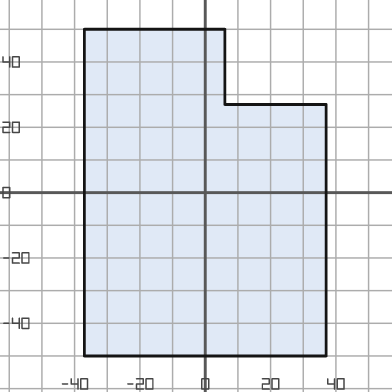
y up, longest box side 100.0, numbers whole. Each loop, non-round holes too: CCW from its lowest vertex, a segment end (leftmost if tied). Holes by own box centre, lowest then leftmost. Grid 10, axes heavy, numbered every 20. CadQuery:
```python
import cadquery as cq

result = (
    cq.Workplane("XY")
    .moveTo(-37.0, -50.0)
    .lineTo(37.0, -50.0)
    .lineTo(37.0, 27.0)
    .lineTo(6.0, 27.0)
    .lineTo(6.0, 50.0)
    .lineTo(-37.0, 50.0)
    .close()
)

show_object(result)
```